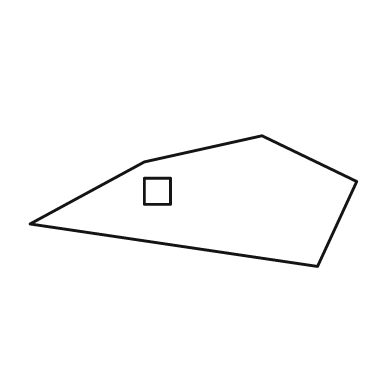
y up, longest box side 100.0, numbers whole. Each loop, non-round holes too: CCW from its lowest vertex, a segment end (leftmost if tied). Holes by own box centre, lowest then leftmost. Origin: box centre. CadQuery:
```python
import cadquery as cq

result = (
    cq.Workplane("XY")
    .moveTo(38.0, -20.0)
    .lineTo(50.0, 6.0)
    .lineTo(21.0, 20.0)
    .lineTo(-15.0, 12.0)
    .lineTo(-50.0, -7.0)
    .close()
    .moveTo(-15.0, -1.0)
    .lineTo(-7.0, -1.0)
    .lineTo(-7.0, 7.0)
    .lineTo(-15.0, 7.0)
    .close()
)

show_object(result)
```